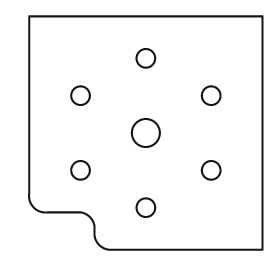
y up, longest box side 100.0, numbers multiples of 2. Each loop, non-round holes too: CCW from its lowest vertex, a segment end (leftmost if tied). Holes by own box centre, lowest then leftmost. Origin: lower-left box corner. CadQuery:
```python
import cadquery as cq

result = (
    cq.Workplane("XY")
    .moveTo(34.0, 0.0)
    .lineTo(100.0, 0.0)
    .lineTo(100.0, 100.0)
    .lineTo(0.0, 100.0)
    .lineTo(0.0, 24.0)
    .threePointArc((2.0, 18.0), (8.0, 16.0))
    .lineTo(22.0, 16.0)
    .threePointArc((26.0, 14.0), (28.0, 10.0))
    .lineTo(28.0, 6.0)
    .threePointArc((30.0, 2.0), (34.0, 0.0))
    .close()
    .moveTo(50.0, 18.0)
    .circle(4.0)
    .moveTo(22.0, 34.0)
    .circle(4.0)
    .moveTo(78.0, 34.0)
    .circle(4.0)
    .moveTo(50.0, 50.0)
    .circle(6.0)
    .moveTo(22.0, 66.0)
    .circle(4.0)
    .moveTo(78.0, 66.0)
    .circle(4.0)
    .moveTo(50.0, 82.0)
    .circle(4.0)
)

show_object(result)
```